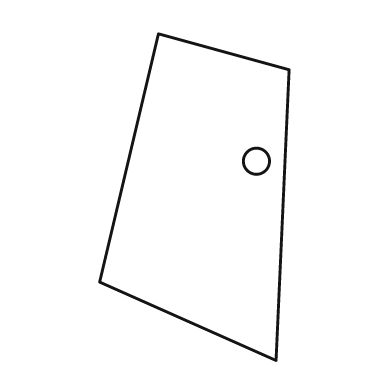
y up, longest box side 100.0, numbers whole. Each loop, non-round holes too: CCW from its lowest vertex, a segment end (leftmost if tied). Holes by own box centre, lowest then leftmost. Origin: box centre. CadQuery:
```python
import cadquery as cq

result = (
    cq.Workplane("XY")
    .moveTo(25.0, -50.0)
    .lineTo(29.0, 39.0)
    .lineTo(-11.0, 50.0)
    .lineTo(-29.0, -26.0)
    .close()
    .moveTo(19.0, 11.0)
    .circle(4.0)
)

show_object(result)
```